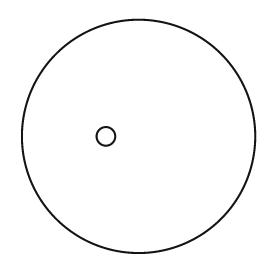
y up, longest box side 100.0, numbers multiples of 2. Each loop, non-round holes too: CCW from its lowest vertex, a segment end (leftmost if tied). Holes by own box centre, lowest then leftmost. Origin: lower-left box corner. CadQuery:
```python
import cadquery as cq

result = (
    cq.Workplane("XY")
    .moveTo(50.0, 50.0)
    .circle(50.0)
    .moveTo(36.0, 50.0)
    .circle(4.0)
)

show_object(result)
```